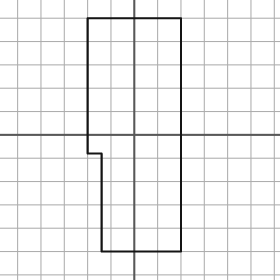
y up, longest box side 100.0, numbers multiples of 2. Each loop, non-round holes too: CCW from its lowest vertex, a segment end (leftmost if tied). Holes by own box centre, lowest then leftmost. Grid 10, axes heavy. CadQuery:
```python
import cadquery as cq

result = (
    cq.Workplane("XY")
    .moveTo(-14.0, -50.0)
    .lineTo(20.0, -50.0)
    .lineTo(20.0, 50.0)
    .lineTo(-20.0, 50.0)
    .lineTo(-20.0, -8.0)
    .lineTo(-14.0, -8.0)
    .close()
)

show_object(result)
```